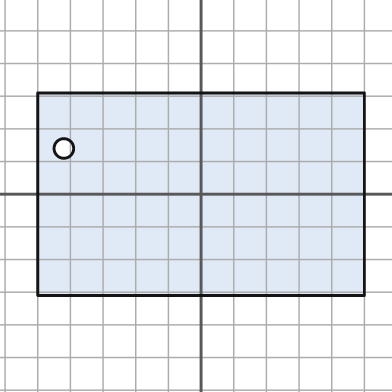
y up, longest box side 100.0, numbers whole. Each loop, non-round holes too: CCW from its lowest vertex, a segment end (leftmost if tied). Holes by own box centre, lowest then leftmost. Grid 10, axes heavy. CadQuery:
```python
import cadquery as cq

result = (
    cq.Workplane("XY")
    .moveTo(-50.0, -31.0)
    .lineTo(50.0, -31.0)
    .lineTo(50.0, 31.0)
    .lineTo(-50.0, 31.0)
    .close()
    .moveTo(-42.0, 14.0)
    .circle(3.0)
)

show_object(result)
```